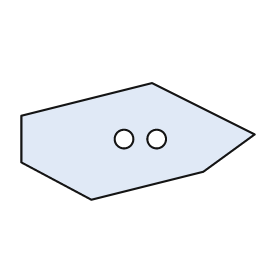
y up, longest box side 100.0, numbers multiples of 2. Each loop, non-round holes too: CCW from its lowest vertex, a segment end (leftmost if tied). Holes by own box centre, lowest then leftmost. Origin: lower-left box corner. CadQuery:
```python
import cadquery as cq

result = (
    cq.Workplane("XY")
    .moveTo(30.0, 0.0)
    .lineTo(78.0, 12.0)
    .lineTo(100.0, 28.0)
    .lineTo(56.0, 50.0)
    .lineTo(0.0, 36.0)
    .lineTo(0.0, 16.0)
    .close()
    .moveTo(44.0, 26.0)
    .circle(4.0)
    .moveTo(58.0, 26.0)
    .circle(4.0)
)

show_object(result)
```